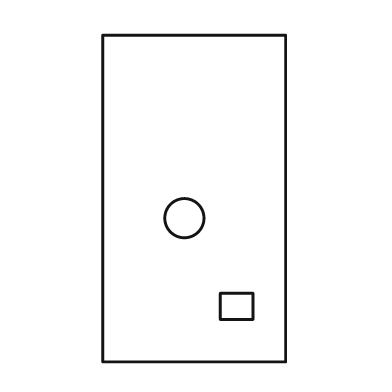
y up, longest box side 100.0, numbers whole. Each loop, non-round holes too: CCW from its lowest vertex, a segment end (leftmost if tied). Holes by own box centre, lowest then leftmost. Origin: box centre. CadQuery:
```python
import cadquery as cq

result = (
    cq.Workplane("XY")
    .moveTo(-28.0, -50.0)
    .lineTo(28.0, -50.0)
    .lineTo(28.0, 50.0)
    .lineTo(-28.0, 50.0)
    .close()
    .moveTo(8.0, -37.0)
    .lineTo(18.0, -37.0)
    .lineTo(18.0, -29.0)
    .lineTo(8.0, -29.0)
    .close()
    .moveTo(-3.0, -6.0)
    .circle(6.0)
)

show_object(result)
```